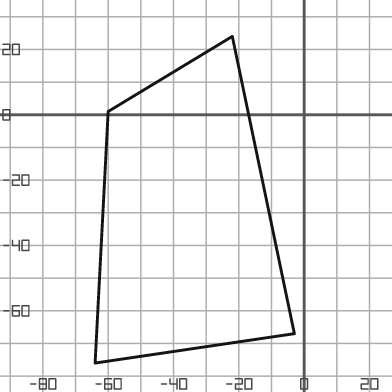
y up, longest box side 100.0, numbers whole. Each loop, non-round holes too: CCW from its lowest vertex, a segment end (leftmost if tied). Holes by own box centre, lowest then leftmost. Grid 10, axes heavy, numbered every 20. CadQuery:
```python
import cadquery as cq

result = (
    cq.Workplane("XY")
    .moveTo(-64.0, -76.0)
    .lineTo(-3.0, -67.0)
    .lineTo(-22.0, 24.0)
    .lineTo(-60.0, 1.0)
    .close()
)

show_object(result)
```